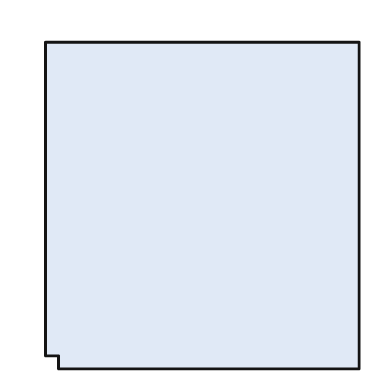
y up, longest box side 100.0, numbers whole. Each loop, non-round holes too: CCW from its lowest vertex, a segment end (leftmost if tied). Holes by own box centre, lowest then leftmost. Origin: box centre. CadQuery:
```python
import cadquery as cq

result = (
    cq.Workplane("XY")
    .moveTo(-44.0, -50.0)
    .lineTo(48.0, -50.0)
    .lineTo(48.0, 50.0)
    .lineTo(-48.0, 50.0)
    .lineTo(-48.0, -46.0)
    .lineTo(-44.0, -46.0)
    .close()
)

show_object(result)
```